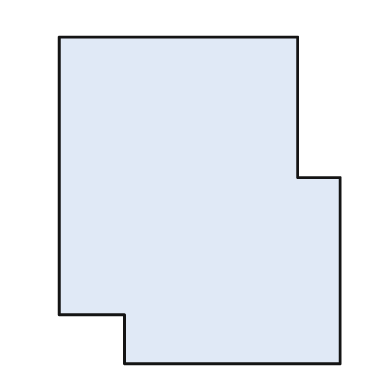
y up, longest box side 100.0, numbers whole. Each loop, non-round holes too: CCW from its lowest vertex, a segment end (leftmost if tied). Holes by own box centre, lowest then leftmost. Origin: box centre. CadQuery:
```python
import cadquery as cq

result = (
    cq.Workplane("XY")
    .moveTo(-23.0, -50.0)
    .lineTo(43.0, -50.0)
    .lineTo(43.0, 7.0)
    .lineTo(30.0, 7.0)
    .lineTo(30.0, 50.0)
    .lineTo(-43.0, 50.0)
    .lineTo(-43.0, -35.0)
    .lineTo(-23.0, -35.0)
    .close()
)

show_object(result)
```